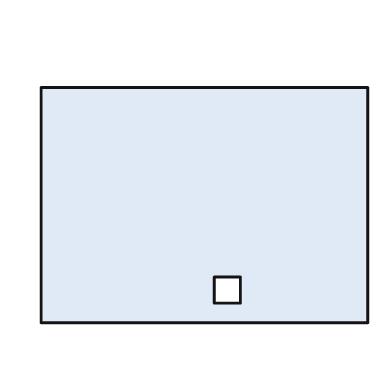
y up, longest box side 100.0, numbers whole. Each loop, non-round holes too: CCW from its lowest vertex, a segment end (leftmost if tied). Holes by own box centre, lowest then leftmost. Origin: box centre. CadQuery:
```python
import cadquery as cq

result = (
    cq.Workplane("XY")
    .moveTo(-50.0, -36.0)
    .lineTo(50.0, -36.0)
    .lineTo(50.0, 36.0)
    .lineTo(-50.0, 36.0)
    .close()
    .moveTo(3.0, -30.0)
    .lineTo(11.0, -30.0)
    .lineTo(11.0, -22.0)
    .lineTo(3.0, -22.0)
    .close()
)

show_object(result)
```